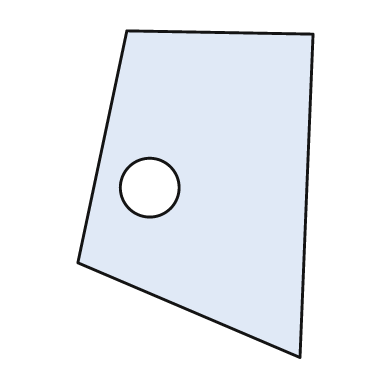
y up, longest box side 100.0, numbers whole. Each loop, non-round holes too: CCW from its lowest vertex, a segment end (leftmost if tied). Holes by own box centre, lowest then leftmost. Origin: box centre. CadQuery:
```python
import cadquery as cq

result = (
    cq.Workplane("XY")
    .moveTo(32.0, -50.0)
    .lineTo(36.0, 49.0)
    .lineTo(-21.0, 50.0)
    .lineTo(-36.0, -21.0)
    .close()
    .moveTo(-14.0, 2.0)
    .circle(9.0)
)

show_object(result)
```